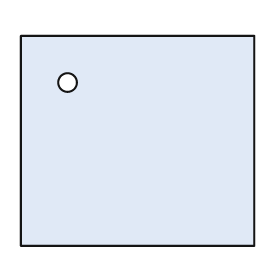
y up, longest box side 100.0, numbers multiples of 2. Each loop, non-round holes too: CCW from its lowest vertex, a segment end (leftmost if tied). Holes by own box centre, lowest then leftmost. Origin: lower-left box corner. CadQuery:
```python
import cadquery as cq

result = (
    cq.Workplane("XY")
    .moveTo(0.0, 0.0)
    .lineTo(100.0, 0.0)
    .lineTo(100.0, 90.0)
    .lineTo(0.0, 90.0)
    .close()
    .moveTo(20.0, 70.0)
    .circle(4.0)
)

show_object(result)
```